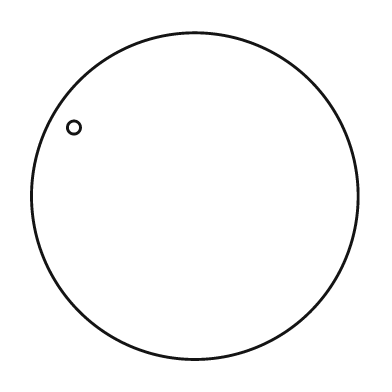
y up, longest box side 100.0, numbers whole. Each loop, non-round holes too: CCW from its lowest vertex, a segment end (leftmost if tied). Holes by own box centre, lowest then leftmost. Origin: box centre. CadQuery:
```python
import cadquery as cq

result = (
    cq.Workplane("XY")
    .moveTo(0.0, 0.0)
    .circle(50.0)
    .moveTo(-37.0, 21.0)
    .circle(2.0)
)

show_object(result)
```